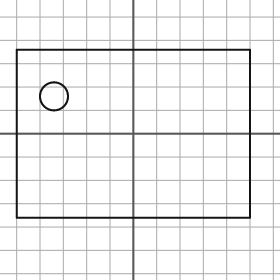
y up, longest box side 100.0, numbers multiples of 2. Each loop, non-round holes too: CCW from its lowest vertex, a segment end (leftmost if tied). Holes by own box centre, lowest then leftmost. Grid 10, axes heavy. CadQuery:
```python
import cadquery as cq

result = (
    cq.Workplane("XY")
    .moveTo(-50.0, -36.0)
    .lineTo(50.0, -36.0)
    .lineTo(50.0, 36.0)
    .lineTo(-50.0, 36.0)
    .close()
    .moveTo(-34.0, 16.0)
    .circle(6.0)
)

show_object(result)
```